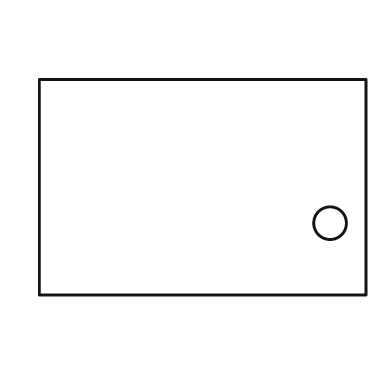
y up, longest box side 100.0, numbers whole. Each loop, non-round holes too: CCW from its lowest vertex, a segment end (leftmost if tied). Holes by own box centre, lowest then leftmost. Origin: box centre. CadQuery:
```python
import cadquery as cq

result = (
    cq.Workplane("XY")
    .moveTo(-50.0, -33.0)
    .lineTo(50.0, -33.0)
    .lineTo(50.0, 33.0)
    .lineTo(-50.0, 33.0)
    .close()
    .moveTo(39.0, -11.0)
    .circle(5.0)
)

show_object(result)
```